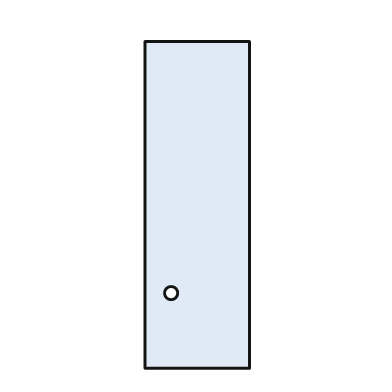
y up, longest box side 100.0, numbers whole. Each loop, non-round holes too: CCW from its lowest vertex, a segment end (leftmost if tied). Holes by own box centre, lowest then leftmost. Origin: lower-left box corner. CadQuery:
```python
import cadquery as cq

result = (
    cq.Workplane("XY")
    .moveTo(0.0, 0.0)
    .lineTo(32.0, 0.0)
    .lineTo(32.0, 100.0)
    .lineTo(0.0, 100.0)
    .close()
    .moveTo(8.0, 23.0)
    .circle(2.0)
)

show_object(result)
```